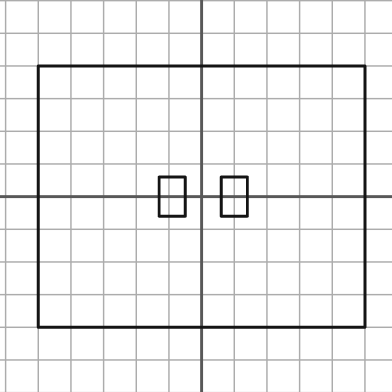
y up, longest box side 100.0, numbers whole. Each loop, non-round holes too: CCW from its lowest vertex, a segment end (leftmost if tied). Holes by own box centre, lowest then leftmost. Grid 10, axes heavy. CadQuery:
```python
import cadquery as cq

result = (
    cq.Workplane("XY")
    .moveTo(-50.0, -40.0)
    .lineTo(50.0, -40.0)
    .lineTo(50.0, 40.0)
    .lineTo(-50.0, 40.0)
    .close()
    .moveTo(-13.0, -6.0)
    .lineTo(-5.0, -6.0)
    .lineTo(-5.0, 6.0)
    .lineTo(-13.0, 6.0)
    .close()
    .moveTo(6.0, -6.0)
    .lineTo(14.0, -6.0)
    .lineTo(14.0, 6.0)
    .lineTo(6.0, 6.0)
    .close()
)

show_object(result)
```